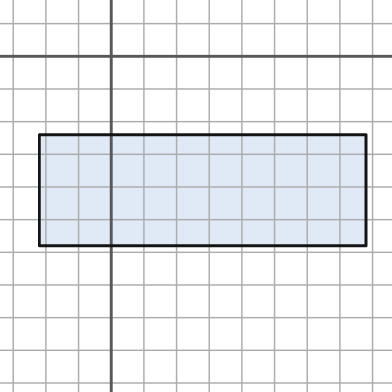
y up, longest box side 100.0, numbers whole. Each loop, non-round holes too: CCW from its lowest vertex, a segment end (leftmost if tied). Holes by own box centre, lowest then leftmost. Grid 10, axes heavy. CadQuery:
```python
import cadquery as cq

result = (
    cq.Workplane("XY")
    .moveTo(-22.0, -58.0)
    .lineTo(78.0, -58.0)
    .lineTo(78.0, -24.0)
    .lineTo(-22.0, -24.0)
    .close()
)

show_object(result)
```